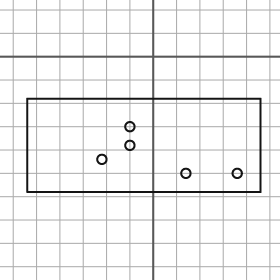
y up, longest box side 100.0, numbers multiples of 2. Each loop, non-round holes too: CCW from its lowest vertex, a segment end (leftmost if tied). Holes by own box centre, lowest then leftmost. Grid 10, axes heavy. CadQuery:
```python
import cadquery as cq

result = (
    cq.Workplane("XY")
    .moveTo(-54.0, -58.0)
    .lineTo(46.0, -58.0)
    .lineTo(46.0, -18.0)
    .lineTo(-54.0, -18.0)
    .close()
    .moveTo(14.0, -50.0)
    .circle(2.0)
    .moveTo(36.0, -50.0)
    .circle(2.0)
    .moveTo(-22.0, -44.0)
    .circle(2.0)
    .moveTo(-10.0, -38.0)
    .circle(2.0)
    .moveTo(-10.0, -30.0)
    .circle(2.0)
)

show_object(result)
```